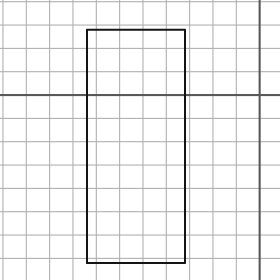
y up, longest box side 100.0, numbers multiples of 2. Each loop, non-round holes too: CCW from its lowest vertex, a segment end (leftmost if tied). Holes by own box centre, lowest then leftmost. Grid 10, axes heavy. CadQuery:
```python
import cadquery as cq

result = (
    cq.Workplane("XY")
    .moveTo(-74.0, -72.0)
    .lineTo(-32.0, -72.0)
    .lineTo(-32.0, 28.0)
    .lineTo(-74.0, 28.0)
    .close()
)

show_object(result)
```